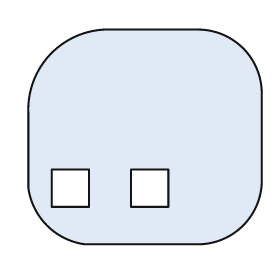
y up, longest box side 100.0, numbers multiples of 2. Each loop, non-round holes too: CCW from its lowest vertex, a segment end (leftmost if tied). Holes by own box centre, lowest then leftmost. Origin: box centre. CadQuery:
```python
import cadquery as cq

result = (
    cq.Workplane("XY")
    .moveTo(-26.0, -46.0)
    .lineTo(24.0, -46.0)
    .threePointArc((42.0, -38.0), (50.0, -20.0))
    .lineTo(50.0, 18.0)
    .threePointArc((42.0, 38.0), (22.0, 46.0))
    .lineTo(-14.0, 46.0)
    .threePointArc((-40.0, 36.0), (-50.0, 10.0))
    .lineTo(-50.0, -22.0)
    .threePointArc((-42.0, -38.0), (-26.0, -46.0))
    .close()
    .moveTo(-40.0, -30.0)
    .lineTo(-24.0, -30.0)
    .lineTo(-24.0, -14.0)
    .lineTo(-40.0, -14.0)
    .close()
    .moveTo(-6.0, -30.0)
    .lineTo(10.0, -30.0)
    .lineTo(10.0, -14.0)
    .lineTo(-6.0, -14.0)
    .close()
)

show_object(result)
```